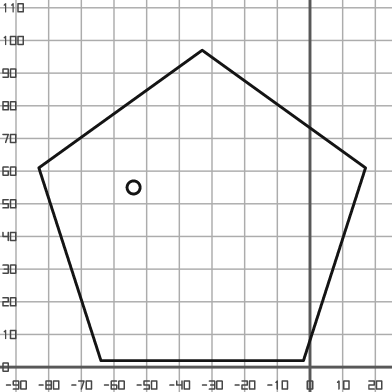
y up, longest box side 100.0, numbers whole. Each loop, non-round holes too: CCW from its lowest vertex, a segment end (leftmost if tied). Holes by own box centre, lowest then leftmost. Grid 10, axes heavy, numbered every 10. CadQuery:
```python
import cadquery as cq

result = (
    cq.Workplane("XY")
    .moveTo(-64.0, 2.0)
    .lineTo(-2.0, 2.0)
    .lineTo(17.0, 61.0)
    .lineTo(-33.0, 97.0)
    .lineTo(-83.0, 61.0)
    .close()
    .moveTo(-54.0, 55.0)
    .circle(2.0)
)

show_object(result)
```